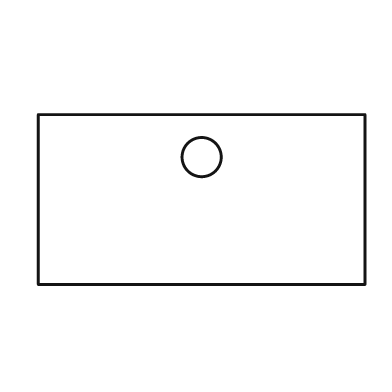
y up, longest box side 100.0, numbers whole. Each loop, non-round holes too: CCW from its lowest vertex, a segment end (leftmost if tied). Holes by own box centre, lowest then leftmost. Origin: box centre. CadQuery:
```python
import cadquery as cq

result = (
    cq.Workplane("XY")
    .moveTo(-50.0, -26.0)
    .lineTo(50.0, -26.0)
    .lineTo(50.0, 26.0)
    .lineTo(-50.0, 26.0)
    .close()
    .moveTo(0.0, 13.0)
    .circle(6.0)
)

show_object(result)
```